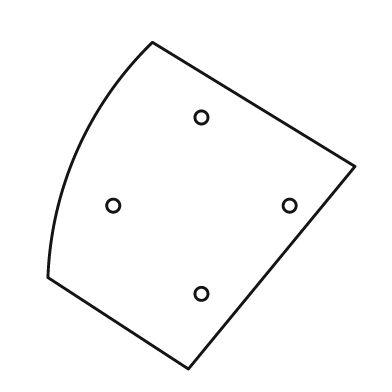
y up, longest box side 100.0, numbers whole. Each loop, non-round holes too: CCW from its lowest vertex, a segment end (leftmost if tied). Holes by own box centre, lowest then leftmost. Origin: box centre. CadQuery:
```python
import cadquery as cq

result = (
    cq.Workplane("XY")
    .moveTo(-4.0, -50.0)
    .lineTo(47.0, 12.0)
    .lineTo(-15.0, 50.0)
    .threePointArc((-38.0, 17.0), (-47.0, -22.0))
    .close()
    .moveTo(0.0, -27.0)
    .circle(2.0)
    .moveTo(-27.0, 0.0)
    .circle(2.0)
    .moveTo(27.0, 0.0)
    .circle(2.0)
    .moveTo(0.0, 27.0)
    .circle(2.0)
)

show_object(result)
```